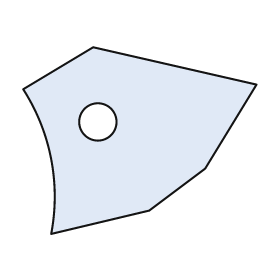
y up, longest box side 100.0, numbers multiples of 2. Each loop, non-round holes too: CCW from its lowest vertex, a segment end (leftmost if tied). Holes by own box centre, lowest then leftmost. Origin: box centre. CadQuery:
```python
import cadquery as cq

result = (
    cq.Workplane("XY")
    .moveTo(-38.0, -40.0)
    .lineTo(4.0, -30.0)
    .lineTo(28.0, -12.0)
    .lineTo(50.0, 24.0)
    .lineTo(-20.0, 40.0)
    .lineTo(-50.0, 22.0)
    .threePointArc((-38.0, -8.0), (-38.0, -40.0))
    .close()
    .moveTo(-18.0, 8.0)
    .circle(8.0)
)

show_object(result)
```